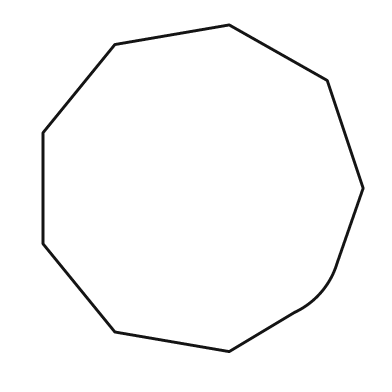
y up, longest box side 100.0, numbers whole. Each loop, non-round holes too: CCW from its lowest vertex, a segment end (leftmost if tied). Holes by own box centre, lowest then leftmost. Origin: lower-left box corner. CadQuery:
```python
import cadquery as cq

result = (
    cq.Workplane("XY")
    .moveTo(57.0, 0.0)
    .lineTo(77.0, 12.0)
    .threePointArc((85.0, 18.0), (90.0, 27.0))
    .lineTo(98.0, 50.0)
    .lineTo(87.0, 83.0)
    .lineTo(57.0, 100.0)
    .lineTo(22.0, 94.0)
    .lineTo(0.0, 67.0)
    .lineTo(0.0, 33.0)
    .lineTo(22.0, 6.0)
    .close()
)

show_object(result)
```